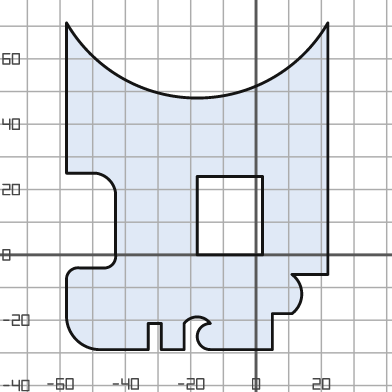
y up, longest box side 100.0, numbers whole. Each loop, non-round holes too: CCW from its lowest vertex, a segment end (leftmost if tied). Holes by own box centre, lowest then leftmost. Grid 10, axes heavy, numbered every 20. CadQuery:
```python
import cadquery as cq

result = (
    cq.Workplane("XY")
    .moveTo(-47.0, -29.0)
    .lineTo(-33.0, -29.0)
    .lineTo(-33.0, -21.0)
    .lineTo(-29.0, -21.0)
    .lineTo(-29.0, -29.0)
    .lineTo(-22.0, -29.0)
    .lineTo(-22.0, -21.0)
    .threePointArc((-18.0, -19.0), (-14.0, -21.0))
    .threePointArc((-18.0, -25.0), (-14.0, -29.0))
    .lineTo(5.0, -29.0)
    .lineTo(5.0, -18.0)
    .lineTo(11.0, -18.0)
    .threePointArc((14.0, -12.0), (11.0, -6.0))
    .lineTo(22.0, -6.0)
    .lineTo(22.0, 71.0)
    .threePointArc((-18.0, 48.0), (-58.0, 71.0))
    .lineTo(-58.0, 25.0)
    .lineTo(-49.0, 25.0)
    .threePointArc((-45.0, 23.0), (-43.0, 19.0))
    .lineTo(-43.0, 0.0)
    .threePointArc((-44.0, -3.0), (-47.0, -4.0))
    .lineTo(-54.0, -4.0)
    .threePointArc((-57.0, -5.0), (-58.0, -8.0))
    .lineTo(-58.0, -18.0)
    .threePointArc((-55.0, -26.0), (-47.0, -29.0))
    .close()
    .moveTo(-18.0, 0.0)
    .lineTo(2.0, 0.0)
    .lineTo(2.0, 24.0)
    .lineTo(-18.0, 24.0)
    .close()
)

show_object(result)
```